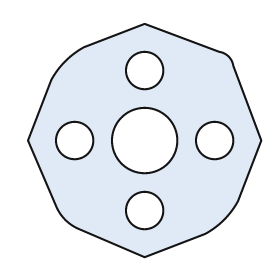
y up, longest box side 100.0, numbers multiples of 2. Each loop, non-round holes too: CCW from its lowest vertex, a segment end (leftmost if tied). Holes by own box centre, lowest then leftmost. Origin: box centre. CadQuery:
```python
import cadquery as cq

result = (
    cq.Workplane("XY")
    .moveTo(0.0, -50.0)
    .lineTo(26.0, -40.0)
    .threePointArc((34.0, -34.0), (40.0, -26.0))
    .lineTo(50.0, 0.0)
    .lineTo(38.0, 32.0)
    .threePointArc((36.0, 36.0), (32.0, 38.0))
    .lineTo(0.0, 50.0)
    .lineTo(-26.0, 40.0)
    .threePointArc((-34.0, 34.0), (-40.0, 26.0))
    .lineTo(-50.0, 0.0)
    .lineTo(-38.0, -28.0)
    .threePointArc((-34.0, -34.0), (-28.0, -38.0))
    .close()
    .moveTo(0.0, -30.0)
    .circle(8.0)
    .moveTo(-30.0, 0.0)
    .circle(8.0)
    .moveTo(0.0, 0.0)
    .circle(14.0)
    .moveTo(30.0, 0.0)
    .circle(8.0)
    .moveTo(0.0, 30.0)
    .circle(8.0)
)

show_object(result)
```